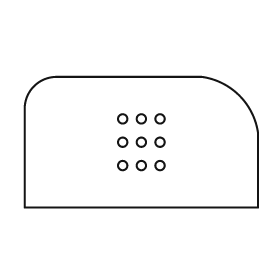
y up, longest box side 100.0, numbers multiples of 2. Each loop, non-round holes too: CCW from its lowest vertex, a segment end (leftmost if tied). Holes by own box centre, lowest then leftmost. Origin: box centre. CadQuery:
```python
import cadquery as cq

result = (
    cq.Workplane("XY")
    .moveTo(-50.0, -28.0)
    .lineTo(50.0, -28.0)
    .lineTo(50.0, 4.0)
    .threePointArc((42.0, 20.0), (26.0, 28.0))
    .lineTo(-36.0, 28.0)
    .threePointArc((-46.0, 24.0), (-50.0, 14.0))
    .close()
    .moveTo(-8.0, -10.0)
    .circle(2.0)
    .moveTo(0.0, -10.0)
    .circle(2.0)
    .moveTo(8.0, -10.0)
    .circle(2.0)
    .moveTo(-8.0, 0.0)
    .circle(2.0)
    .moveTo(0.0, 0.0)
    .circle(2.0)
    .moveTo(8.0, 0.0)
    .circle(2.0)
    .moveTo(-8.0, 10.0)
    .circle(2.0)
    .moveTo(0.0, 10.0)
    .circle(2.0)
    .moveTo(8.0, 10.0)
    .circle(2.0)
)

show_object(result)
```